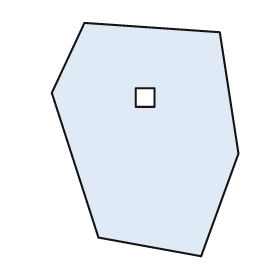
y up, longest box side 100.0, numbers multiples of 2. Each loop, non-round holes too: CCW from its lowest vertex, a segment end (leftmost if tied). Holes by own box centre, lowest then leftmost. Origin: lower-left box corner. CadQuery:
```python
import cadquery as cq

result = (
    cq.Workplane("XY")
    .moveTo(64.0, 0.0)
    .lineTo(80.0, 44.0)
    .lineTo(72.0, 96.0)
    .lineTo(14.0, 100.0)
    .lineTo(0.0, 70.0)
    .lineTo(20.0, 8.0)
    .close()
    .moveTo(36.0, 64.0)
    .lineTo(44.0, 64.0)
    .lineTo(44.0, 72.0)
    .lineTo(36.0, 72.0)
    .close()
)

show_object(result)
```